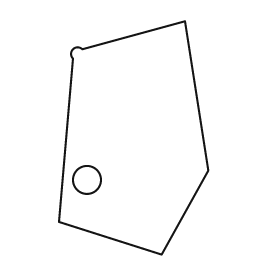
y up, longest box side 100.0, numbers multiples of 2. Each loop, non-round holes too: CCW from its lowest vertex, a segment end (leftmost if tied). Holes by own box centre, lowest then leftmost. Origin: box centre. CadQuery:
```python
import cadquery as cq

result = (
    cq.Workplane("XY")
    .moveTo(12.0, -50.0)
    .lineTo(32.0, -14.0)
    .lineTo(22.0, 50.0)
    .lineTo(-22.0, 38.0)
    .threePointArc((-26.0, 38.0), (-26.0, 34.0))
    .lineTo(-32.0, -36.0)
    .close()
    .moveTo(-20.0, -18.0)
    .circle(6.0)
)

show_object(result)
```